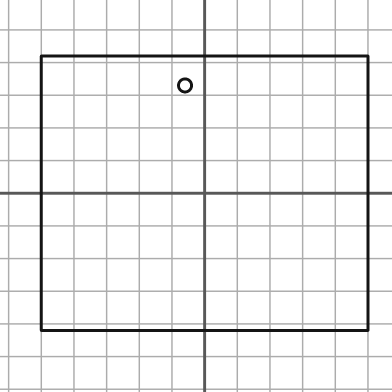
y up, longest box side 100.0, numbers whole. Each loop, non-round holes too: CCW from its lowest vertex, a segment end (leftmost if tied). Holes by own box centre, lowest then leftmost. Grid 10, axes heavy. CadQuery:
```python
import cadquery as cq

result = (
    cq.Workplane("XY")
    .moveTo(-50.0, -42.0)
    .lineTo(50.0, -42.0)
    .lineTo(50.0, 42.0)
    .lineTo(-50.0, 42.0)
    .close()
    .moveTo(-6.0, 33.0)
    .circle(2.0)
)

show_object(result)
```